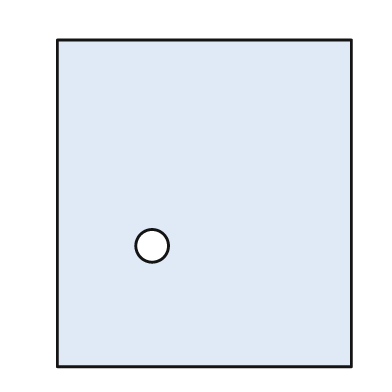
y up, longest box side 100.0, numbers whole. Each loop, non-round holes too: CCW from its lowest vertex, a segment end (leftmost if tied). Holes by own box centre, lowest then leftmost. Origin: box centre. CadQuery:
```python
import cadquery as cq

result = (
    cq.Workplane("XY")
    .moveTo(-45.0, -50.0)
    .lineTo(45.0, -50.0)
    .lineTo(45.0, 50.0)
    .lineTo(-45.0, 50.0)
    .close()
    .moveTo(-16.0, -13.0)
    .circle(5.0)
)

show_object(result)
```